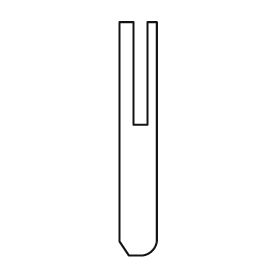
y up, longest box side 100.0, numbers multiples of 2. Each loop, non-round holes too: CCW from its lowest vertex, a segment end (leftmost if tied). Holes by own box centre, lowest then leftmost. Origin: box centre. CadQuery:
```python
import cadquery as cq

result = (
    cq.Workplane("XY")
    .moveTo(-4.0, -50.0)
    .lineTo(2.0, -50.0)
    .threePointArc((6.0, -48.0), (8.0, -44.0))
    .lineTo(8.0, 50.0)
    .lineTo(4.0, 50.0)
    .lineTo(4.0, 6.0)
    .lineTo(-2.0, 6.0)
    .lineTo(-2.0, 50.0)
    .lineTo(-8.0, 50.0)
    .lineTo(-8.0, -44.0)
    .close()
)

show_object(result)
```